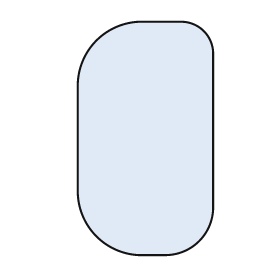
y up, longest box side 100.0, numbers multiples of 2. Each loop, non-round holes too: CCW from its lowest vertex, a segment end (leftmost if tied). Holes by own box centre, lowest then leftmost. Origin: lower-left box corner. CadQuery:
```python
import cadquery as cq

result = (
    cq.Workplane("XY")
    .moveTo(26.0, 0.0)
    .lineTo(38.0, 0.0)
    .threePointArc((52.0, 6.0), (58.0, 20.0))
    .lineTo(58.0, 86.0)
    .threePointArc((54.0, 96.0), (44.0, 100.0))
    .lineTo(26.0, 100.0)
    .threePointArc((8.0, 92.0), (0.0, 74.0))
    .lineTo(0.0, 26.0)
    .threePointArc((8.0, 8.0), (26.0, 0.0))
    .close()
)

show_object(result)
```